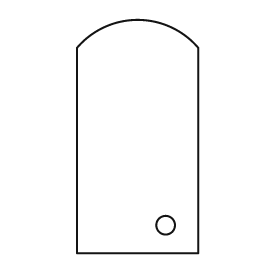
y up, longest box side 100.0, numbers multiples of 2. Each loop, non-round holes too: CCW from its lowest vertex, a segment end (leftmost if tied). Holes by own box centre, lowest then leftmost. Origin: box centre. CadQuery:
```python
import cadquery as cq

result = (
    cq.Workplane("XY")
    .moveTo(-26.0, -50.0)
    .lineTo(26.0, -50.0)
    .lineTo(26.0, 38.0)
    .threePointArc((0.0, 50.0), (-26.0, 38.0))
    .close()
    .moveTo(12.0, -38.0)
    .circle(4.0)
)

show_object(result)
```